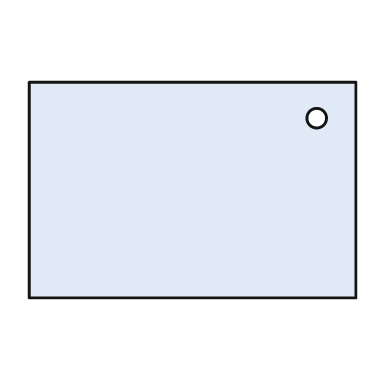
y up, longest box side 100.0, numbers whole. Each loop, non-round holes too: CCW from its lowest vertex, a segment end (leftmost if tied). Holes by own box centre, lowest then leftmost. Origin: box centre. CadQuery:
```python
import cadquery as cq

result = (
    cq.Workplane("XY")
    .moveTo(-50.0, -33.0)
    .lineTo(50.0, -33.0)
    .lineTo(50.0, 33.0)
    .lineTo(-50.0, 33.0)
    .close()
    .moveTo(38.0, 22.0)
    .circle(3.0)
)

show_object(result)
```